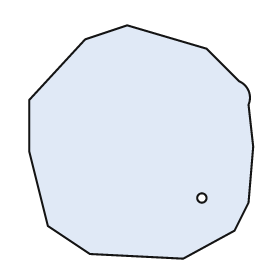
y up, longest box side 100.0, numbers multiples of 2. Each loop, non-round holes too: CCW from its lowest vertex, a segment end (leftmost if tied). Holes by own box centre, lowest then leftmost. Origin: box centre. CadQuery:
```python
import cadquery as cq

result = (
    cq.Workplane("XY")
    .moveTo(18.0, -50.0)
    .lineTo(40.0, -38.0)
    .lineTo(46.0, -26.0)
    .lineTo(48.0, -2.0)
    .lineTo(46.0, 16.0)
    .threePointArc((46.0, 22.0), (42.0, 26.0))
    .lineTo(28.0, 40.0)
    .lineTo(-6.0, 50.0)
    .lineTo(-24.0, 44.0)
    .lineTo(-48.0, 18.0)
    .lineTo(-48.0, -4.0)
    .lineTo(-40.0, -36.0)
    .lineTo(-22.0, -48.0)
    .close()
    .moveTo(26.0, -24.0)
    .circle(2.0)
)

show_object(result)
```